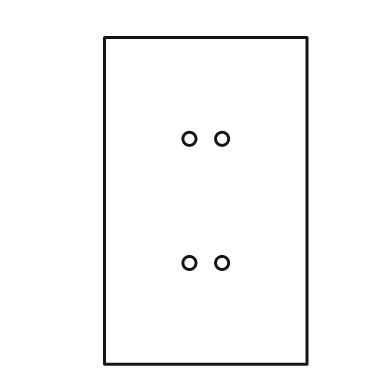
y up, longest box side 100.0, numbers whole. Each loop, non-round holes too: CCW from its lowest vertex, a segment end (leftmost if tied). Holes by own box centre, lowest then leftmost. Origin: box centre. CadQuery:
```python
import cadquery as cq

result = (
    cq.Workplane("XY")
    .moveTo(-31.0, -50.0)
    .lineTo(31.0, -50.0)
    .lineTo(31.0, 50.0)
    .lineTo(-31.0, 50.0)
    .close()
    .moveTo(-5.0, -19.0)
    .circle(2.0)
    .moveTo(5.0, -19.0)
    .circle(2.0)
    .moveTo(-5.0, 19.0)
    .circle(2.0)
    .moveTo(5.0, 19.0)
    .circle(2.0)
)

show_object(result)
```